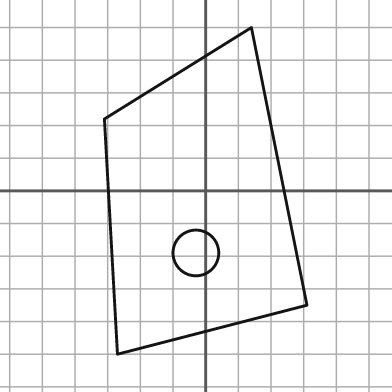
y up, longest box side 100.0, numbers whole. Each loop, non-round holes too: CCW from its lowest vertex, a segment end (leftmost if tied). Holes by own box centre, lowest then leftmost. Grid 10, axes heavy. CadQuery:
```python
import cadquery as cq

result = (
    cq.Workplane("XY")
    .moveTo(-27.0, -50.0)
    .lineTo(31.0, -35.0)
    .lineTo(14.0, 50.0)
    .lineTo(-31.0, 22.0)
    .close()
    .moveTo(-3.0, -19.0)
    .circle(7.0)
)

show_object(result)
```